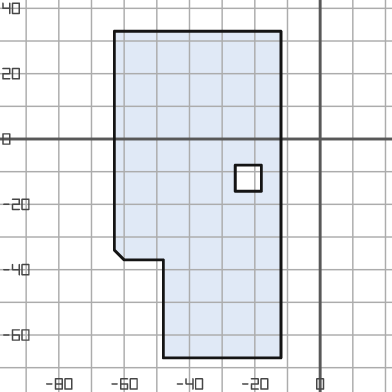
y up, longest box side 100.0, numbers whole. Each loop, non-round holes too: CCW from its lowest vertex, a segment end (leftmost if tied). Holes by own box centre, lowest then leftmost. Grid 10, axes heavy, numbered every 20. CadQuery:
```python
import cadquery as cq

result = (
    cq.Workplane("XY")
    .moveTo(-48.0, -67.0)
    .lineTo(-12.0, -67.0)
    .lineTo(-12.0, 33.0)
    .lineTo(-63.0, 33.0)
    .lineTo(-63.0, -34.0)
    .lineTo(-60.0, -37.0)
    .lineTo(-48.0, -37.0)
    .close()
    .moveTo(-26.0, -16.0)
    .lineTo(-18.0, -16.0)
    .lineTo(-18.0, -8.0)
    .lineTo(-26.0, -8.0)
    .close()
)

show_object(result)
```